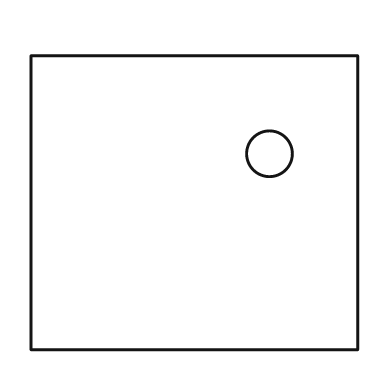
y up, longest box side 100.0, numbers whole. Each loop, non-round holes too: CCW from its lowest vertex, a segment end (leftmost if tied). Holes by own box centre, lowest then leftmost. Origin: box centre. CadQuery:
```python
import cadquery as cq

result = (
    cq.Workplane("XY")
    .moveTo(-50.0, -45.0)
    .lineTo(50.0, -45.0)
    .lineTo(50.0, 45.0)
    .lineTo(-50.0, 45.0)
    .close()
    .moveTo(23.0, 15.0)
    .circle(7.0)
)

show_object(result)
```